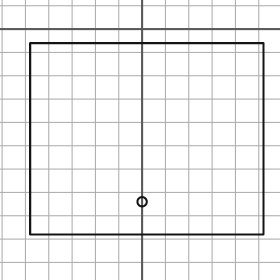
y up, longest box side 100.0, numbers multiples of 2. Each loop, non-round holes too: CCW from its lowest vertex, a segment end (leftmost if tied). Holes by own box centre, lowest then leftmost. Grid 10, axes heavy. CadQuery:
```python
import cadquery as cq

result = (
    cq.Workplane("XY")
    .moveTo(-48.0, -88.0)
    .lineTo(52.0, -88.0)
    .lineTo(52.0, -6.0)
    .lineTo(-48.0, -6.0)
    .close()
    .moveTo(0.0, -74.0)
    .circle(2.0)
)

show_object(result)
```